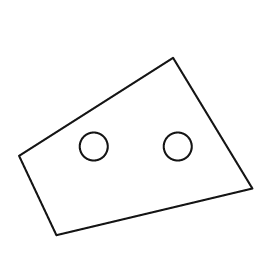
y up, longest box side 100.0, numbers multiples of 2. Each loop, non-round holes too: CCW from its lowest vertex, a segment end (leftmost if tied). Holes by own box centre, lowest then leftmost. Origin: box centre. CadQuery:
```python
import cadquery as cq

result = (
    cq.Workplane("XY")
    .moveTo(-34.0, -38.0)
    .lineTo(50.0, -18.0)
    .lineTo(16.0, 38.0)
    .lineTo(-50.0, -4.0)
    .close()
    .moveTo(-18.0, 0.0)
    .circle(6.0)
    .moveTo(18.0, 0.0)
    .circle(6.0)
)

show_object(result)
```